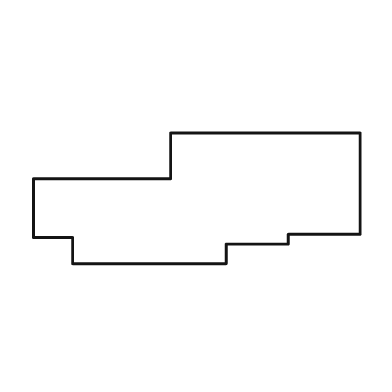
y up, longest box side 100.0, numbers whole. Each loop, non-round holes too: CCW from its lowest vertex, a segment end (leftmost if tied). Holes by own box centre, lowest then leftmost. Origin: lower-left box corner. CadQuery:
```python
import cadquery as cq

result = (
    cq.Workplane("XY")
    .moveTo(12.0, 0.0)
    .lineTo(59.0, 0.0)
    .lineTo(59.0, 6.0)
    .lineTo(78.0, 6.0)
    .lineTo(78.0, 9.0)
    .lineTo(100.0, 9.0)
    .lineTo(100.0, 40.0)
    .lineTo(42.0, 40.0)
    .lineTo(42.0, 26.0)
    .lineTo(0.0, 26.0)
    .lineTo(0.0, 8.0)
    .lineTo(12.0, 8.0)
    .close()
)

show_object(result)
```